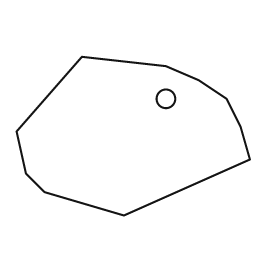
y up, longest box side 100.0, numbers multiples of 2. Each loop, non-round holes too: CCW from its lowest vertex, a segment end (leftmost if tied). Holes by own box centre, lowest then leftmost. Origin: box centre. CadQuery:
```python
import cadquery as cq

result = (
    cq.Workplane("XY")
    .moveTo(-4.0, -34.0)
    .lineTo(50.0, -10.0)
    .lineTo(46.0, 4.0)
    .lineTo(40.0, 16.0)
    .lineTo(28.0, 24.0)
    .lineTo(14.0, 30.0)
    .lineTo(-22.0, 34.0)
    .lineTo(-50.0, 2.0)
    .lineTo(-46.0, -16.0)
    .lineTo(-38.0, -24.0)
    .close()
    .moveTo(14.0, 16.0)
    .circle(4.0)
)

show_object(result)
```